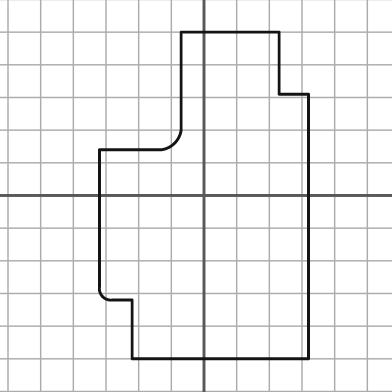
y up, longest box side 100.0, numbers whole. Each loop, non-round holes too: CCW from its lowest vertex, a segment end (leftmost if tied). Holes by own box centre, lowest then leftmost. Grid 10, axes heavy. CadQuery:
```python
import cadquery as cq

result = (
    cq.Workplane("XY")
    .moveTo(-22.0, -50.0)
    .lineTo(32.0, -50.0)
    .lineTo(32.0, 31.0)
    .lineTo(23.0, 31.0)
    .lineTo(23.0, 50.0)
    .lineTo(-7.0, 50.0)
    .lineTo(-7.0, 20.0)
    .threePointArc((-9.0, 16.0), (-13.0, 14.0))
    .lineTo(-32.0, 14.0)
    .lineTo(-32.0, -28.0)
    .threePointArc((-31.0, -31.0), (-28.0, -32.0))
    .lineTo(-22.0, -32.0)
    .close()
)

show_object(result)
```